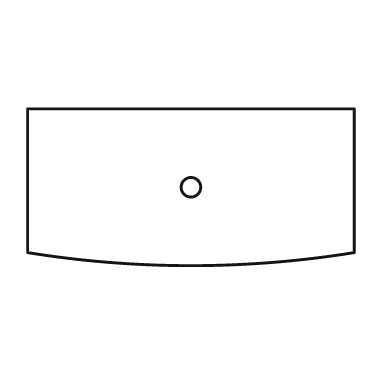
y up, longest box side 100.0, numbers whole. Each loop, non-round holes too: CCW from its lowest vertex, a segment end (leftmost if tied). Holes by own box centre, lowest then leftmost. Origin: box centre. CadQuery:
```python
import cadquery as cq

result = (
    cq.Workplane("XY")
    .moveTo(-50.0, -20.0)
    .threePointArc((0.0, -24.0), (50.0, -20.0))
    .lineTo(50.0, 24.0)
    .lineTo(-50.0, 24.0)
    .close()
    .moveTo(0.0, 0.0)
    .circle(3.0)
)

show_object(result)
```